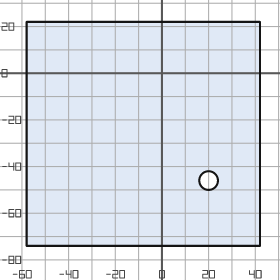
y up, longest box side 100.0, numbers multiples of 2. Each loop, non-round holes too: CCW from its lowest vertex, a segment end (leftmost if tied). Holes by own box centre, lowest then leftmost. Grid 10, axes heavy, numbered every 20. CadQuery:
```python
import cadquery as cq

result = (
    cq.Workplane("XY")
    .moveTo(-58.0, -74.0)
    .lineTo(42.0, -74.0)
    .lineTo(42.0, 22.0)
    .lineTo(-58.0, 22.0)
    .close()
    .moveTo(20.0, -46.0)
    .circle(4.0)
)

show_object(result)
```